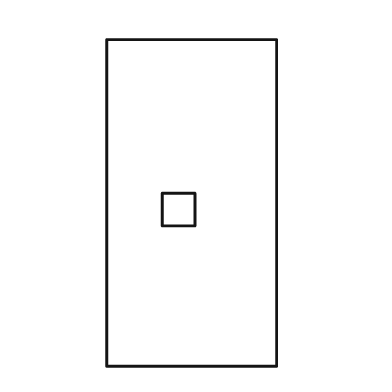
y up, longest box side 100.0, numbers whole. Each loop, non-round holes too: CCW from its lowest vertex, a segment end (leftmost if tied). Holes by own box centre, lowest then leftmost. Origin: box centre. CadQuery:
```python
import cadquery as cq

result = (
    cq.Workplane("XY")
    .moveTo(-26.0, -50.0)
    .lineTo(26.0, -50.0)
    .lineTo(26.0, 50.0)
    .lineTo(-26.0, 50.0)
    .close()
    .moveTo(-9.0, -7.0)
    .lineTo(1.0, -7.0)
    .lineTo(1.0, 3.0)
    .lineTo(-9.0, 3.0)
    .close()
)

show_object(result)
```